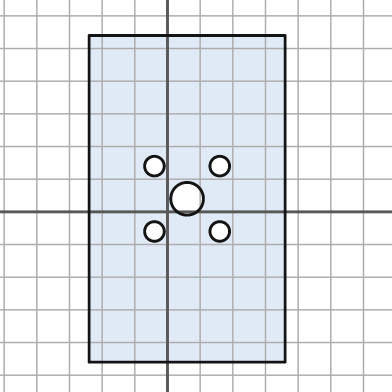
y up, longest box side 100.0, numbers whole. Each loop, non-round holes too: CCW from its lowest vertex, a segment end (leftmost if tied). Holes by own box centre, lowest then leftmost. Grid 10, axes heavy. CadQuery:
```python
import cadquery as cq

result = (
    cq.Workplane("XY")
    .moveTo(-24.0, -46.0)
    .lineTo(36.0, -46.0)
    .lineTo(36.0, 54.0)
    .lineTo(-24.0, 54.0)
    .close()
    .moveTo(-4.0, -6.0)
    .circle(3.0)
    .moveTo(16.0, -6.0)
    .circle(3.0)
    .moveTo(6.0, 4.0)
    .circle(5.0)
    .moveTo(-4.0, 14.0)
    .circle(3.0)
    .moveTo(16.0, 14.0)
    .circle(3.0)
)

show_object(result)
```